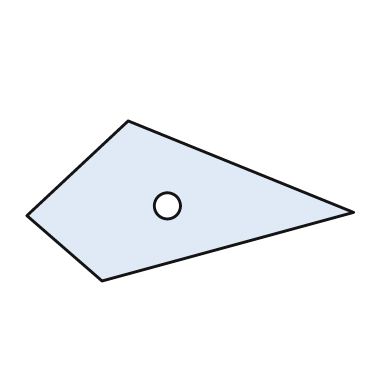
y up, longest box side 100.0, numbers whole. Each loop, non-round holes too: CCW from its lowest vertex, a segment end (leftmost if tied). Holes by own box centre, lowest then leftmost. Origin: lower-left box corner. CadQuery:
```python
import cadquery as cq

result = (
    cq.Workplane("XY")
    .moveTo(23.0, 0.0)
    .lineTo(100.0, 21.0)
    .lineTo(31.0, 49.0)
    .lineTo(0.0, 20.0)
    .close()
    .moveTo(43.0, 23.0)
    .circle(4.0)
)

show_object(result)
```